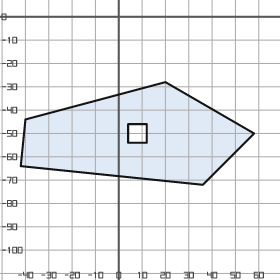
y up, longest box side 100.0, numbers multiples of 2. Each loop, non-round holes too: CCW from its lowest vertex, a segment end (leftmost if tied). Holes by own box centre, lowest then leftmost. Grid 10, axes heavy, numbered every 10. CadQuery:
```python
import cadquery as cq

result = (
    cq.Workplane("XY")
    .moveTo(36.0, -72.0)
    .lineTo(58.0, -50.0)
    .lineTo(20.0, -28.0)
    .lineTo(-40.0, -44.0)
    .lineTo(-42.0, -64.0)
    .close()
    .moveTo(4.0, -54.0)
    .lineTo(12.0, -54.0)
    .lineTo(12.0, -46.0)
    .lineTo(4.0, -46.0)
    .close()
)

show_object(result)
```